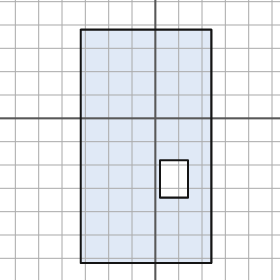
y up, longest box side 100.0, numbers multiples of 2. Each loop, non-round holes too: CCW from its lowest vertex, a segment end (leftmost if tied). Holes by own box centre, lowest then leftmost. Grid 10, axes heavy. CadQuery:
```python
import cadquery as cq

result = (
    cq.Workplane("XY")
    .moveTo(-32.0, -62.0)
    .lineTo(24.0, -62.0)
    .lineTo(24.0, 38.0)
    .lineTo(-32.0, 38.0)
    .close()
    .moveTo(2.0, -34.0)
    .lineTo(14.0, -34.0)
    .lineTo(14.0, -18.0)
    .lineTo(2.0, -18.0)
    .close()
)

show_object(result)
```